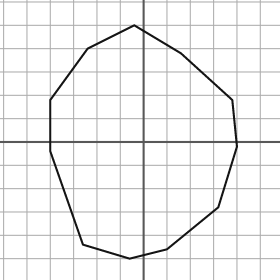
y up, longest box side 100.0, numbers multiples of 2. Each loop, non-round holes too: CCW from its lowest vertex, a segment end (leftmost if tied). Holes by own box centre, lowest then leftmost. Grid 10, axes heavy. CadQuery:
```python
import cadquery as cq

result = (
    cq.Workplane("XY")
    .moveTo(-6.0, -50.0)
    .lineTo(10.0, -46.0)
    .lineTo(32.0, -28.0)
    .lineTo(40.0, -2.0)
    .lineTo(38.0, 18.0)
    .lineTo(16.0, 38.0)
    .lineTo(-4.0, 50.0)
    .lineTo(-24.0, 40.0)
    .lineTo(-40.0, 18.0)
    .lineTo(-40.0, -4.0)
    .lineTo(-26.0, -44.0)
    .close()
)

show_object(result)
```